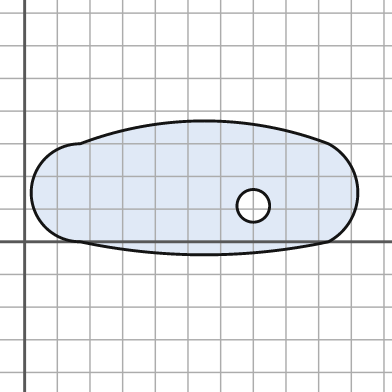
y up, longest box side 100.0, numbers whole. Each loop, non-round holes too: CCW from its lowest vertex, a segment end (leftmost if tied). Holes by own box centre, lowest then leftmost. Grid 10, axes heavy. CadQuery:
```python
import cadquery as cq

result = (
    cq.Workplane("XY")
    .moveTo(17.0, 0.0)
    .threePointArc((55.0, -4.0), (93.0, 0.0))
    .threePointArc((102.0, 15.0), (93.0, 30.0))
    .threePointArc((55.0, 37.0), (17.0, 30.0))
    .threePointArc((2.0, 15.0), (17.0, 0.0))
    .close()
    .moveTo(70.0, 11.0)
    .circle(5.0)
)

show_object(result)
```